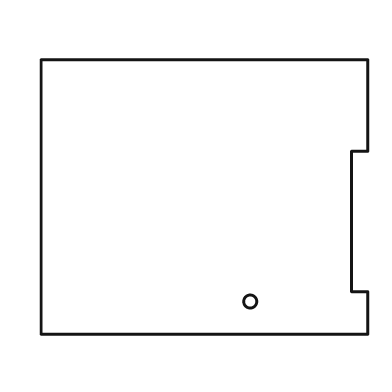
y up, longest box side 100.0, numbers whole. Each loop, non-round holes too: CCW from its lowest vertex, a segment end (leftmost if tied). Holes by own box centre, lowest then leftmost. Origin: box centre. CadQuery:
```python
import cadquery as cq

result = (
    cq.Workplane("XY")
    .moveTo(-50.0, -42.0)
    .lineTo(50.0, -42.0)
    .lineTo(50.0, -29.0)
    .lineTo(45.0, -29.0)
    .lineTo(45.0, 14.0)
    .lineTo(50.0, 14.0)
    .lineTo(50.0, 42.0)
    .lineTo(-50.0, 42.0)
    .close()
    .moveTo(14.0, -32.0)
    .circle(2.0)
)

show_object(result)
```